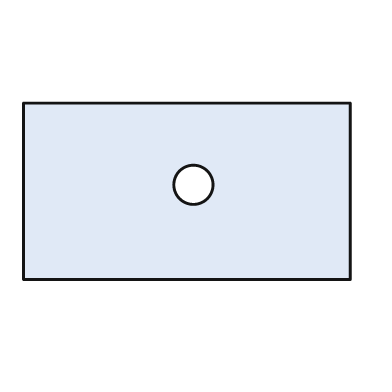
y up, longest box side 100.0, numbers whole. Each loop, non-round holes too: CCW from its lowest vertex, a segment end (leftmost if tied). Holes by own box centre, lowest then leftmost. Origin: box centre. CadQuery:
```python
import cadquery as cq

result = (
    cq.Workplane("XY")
    .moveTo(-50.0, -27.0)
    .lineTo(50.0, -27.0)
    .lineTo(50.0, 27.0)
    .lineTo(-50.0, 27.0)
    .close()
    .moveTo(2.0, 2.0)
    .circle(6.0)
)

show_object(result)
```